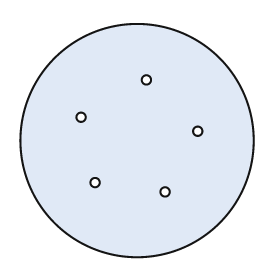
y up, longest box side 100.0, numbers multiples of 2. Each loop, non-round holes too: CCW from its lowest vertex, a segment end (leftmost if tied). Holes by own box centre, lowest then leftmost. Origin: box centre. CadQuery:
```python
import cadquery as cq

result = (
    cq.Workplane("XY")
    .moveTo(0.0, 0.0)
    .circle(50.0)
    .moveTo(12.0, -22.0)
    .circle(2.0)
    .moveTo(-18.0, -18.0)
    .circle(2.0)
    .moveTo(26.0, 4.0)
    .circle(2.0)
    .moveTo(-24.0, 10.0)
    .circle(2.0)
    .moveTo(4.0, 26.0)
    .circle(2.0)
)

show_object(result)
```